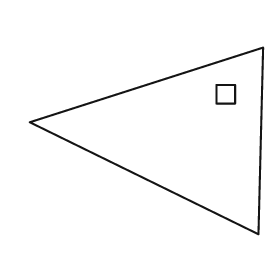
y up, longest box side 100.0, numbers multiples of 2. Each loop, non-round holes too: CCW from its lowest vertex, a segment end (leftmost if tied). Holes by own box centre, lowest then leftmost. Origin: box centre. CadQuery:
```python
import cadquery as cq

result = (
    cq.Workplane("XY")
    .moveTo(48.0, -40.0)
    .lineTo(50.0, 40.0)
    .lineTo(-50.0, 8.0)
    .close()
    .moveTo(30.0, 16.0)
    .lineTo(38.0, 16.0)
    .lineTo(38.0, 24.0)
    .lineTo(30.0, 24.0)
    .close()
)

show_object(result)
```